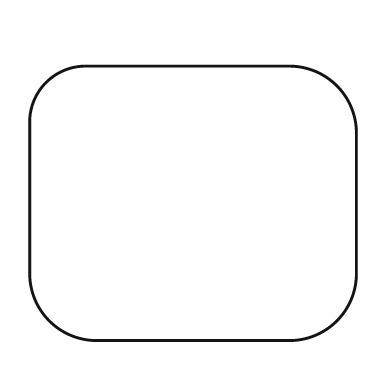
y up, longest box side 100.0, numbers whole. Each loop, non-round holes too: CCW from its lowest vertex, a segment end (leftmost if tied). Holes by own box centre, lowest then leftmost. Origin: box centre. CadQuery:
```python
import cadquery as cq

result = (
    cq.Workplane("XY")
    .moveTo(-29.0, -42.0)
    .lineTo(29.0, -42.0)
    .threePointArc((44.0, -36.0), (50.0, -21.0))
    .lineTo(50.0, 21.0)
    .threePointArc((44.0, 36.0), (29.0, 42.0))
    .lineTo(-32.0, 42.0)
    .threePointArc((-45.0, 37.0), (-50.0, 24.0))
    .lineTo(-50.0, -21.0)
    .threePointArc((-44.0, -36.0), (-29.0, -42.0))
    .close()
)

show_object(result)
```